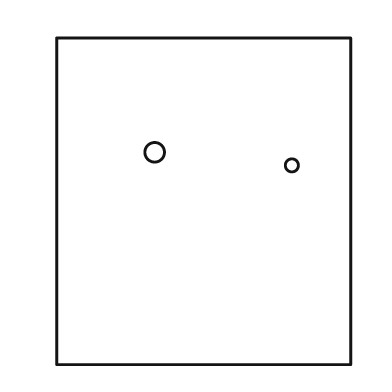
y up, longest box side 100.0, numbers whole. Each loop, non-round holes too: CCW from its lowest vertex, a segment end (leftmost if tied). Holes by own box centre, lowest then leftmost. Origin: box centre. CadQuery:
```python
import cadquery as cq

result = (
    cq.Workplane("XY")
    .moveTo(-45.0, -50.0)
    .lineTo(45.0, -50.0)
    .lineTo(45.0, 50.0)
    .lineTo(-45.0, 50.0)
    .close()
    .moveTo(27.0, 11.0)
    .circle(2.0)
    .moveTo(-15.0, 15.0)
    .circle(3.0)
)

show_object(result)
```